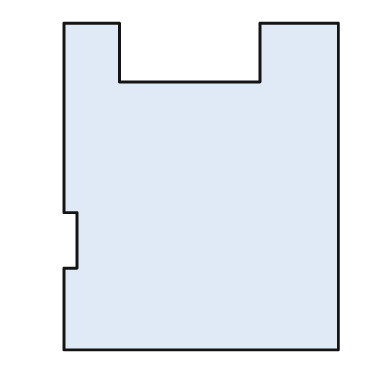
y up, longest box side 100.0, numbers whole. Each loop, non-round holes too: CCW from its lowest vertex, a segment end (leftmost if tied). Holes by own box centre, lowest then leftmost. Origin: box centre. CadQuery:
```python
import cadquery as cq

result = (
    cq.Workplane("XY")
    .moveTo(-42.0, -50.0)
    .lineTo(42.0, -50.0)
    .lineTo(42.0, 50.0)
    .lineTo(18.0, 50.0)
    .lineTo(18.0, 32.0)
    .lineTo(-25.0, 32.0)
    .lineTo(-25.0, 50.0)
    .lineTo(-42.0, 50.0)
    .lineTo(-42.0, -8.0)
    .lineTo(-38.0, -8.0)
    .lineTo(-38.0, -25.0)
    .lineTo(-42.0, -25.0)
    .close()
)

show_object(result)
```